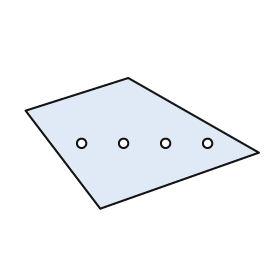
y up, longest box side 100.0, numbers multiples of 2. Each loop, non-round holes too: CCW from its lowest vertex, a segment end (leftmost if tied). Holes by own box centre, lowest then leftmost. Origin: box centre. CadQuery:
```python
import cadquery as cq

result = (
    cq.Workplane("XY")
    .moveTo(-18.0, -28.0)
    .lineTo(50.0, -4.0)
    .lineTo(-6.0, 28.0)
    .lineTo(-50.0, 14.0)
    .close()
    .moveTo(-26.0, 0.0)
    .circle(2.0)
    .moveTo(-8.0, 0.0)
    .circle(2.0)
    .moveTo(10.0, 0.0)
    .circle(2.0)
    .moveTo(28.0, 0.0)
    .circle(2.0)
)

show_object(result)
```